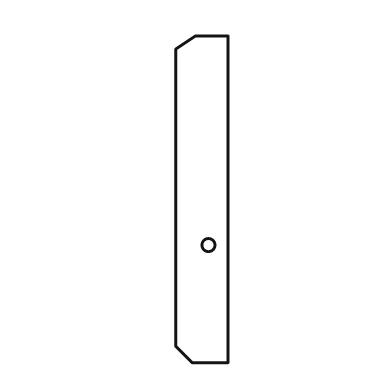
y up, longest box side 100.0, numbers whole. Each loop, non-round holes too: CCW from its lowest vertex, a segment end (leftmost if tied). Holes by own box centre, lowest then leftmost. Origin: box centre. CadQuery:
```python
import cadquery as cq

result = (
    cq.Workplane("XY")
    .moveTo(-3.0, -50.0)
    .lineTo(8.0, -50.0)
    .lineTo(8.0, 50.0)
    .lineTo(-2.0, 50.0)
    .lineTo(-8.0, 46.0)
    .lineTo(-8.0, -45.0)
    .close()
    .moveTo(2.0, -14.0)
    .circle(2.0)
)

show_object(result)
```